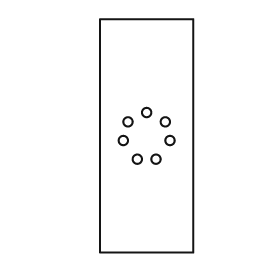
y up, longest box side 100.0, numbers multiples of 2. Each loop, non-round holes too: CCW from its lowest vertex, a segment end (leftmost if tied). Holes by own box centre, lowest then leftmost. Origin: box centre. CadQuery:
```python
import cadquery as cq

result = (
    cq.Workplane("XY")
    .moveTo(-20.0, -50.0)
    .lineTo(20.0, -50.0)
    .lineTo(20.0, 50.0)
    .lineTo(-20.0, 50.0)
    .close()
    .moveTo(-4.0, -10.0)
    .circle(2.0)
    .moveTo(4.0, -10.0)
    .circle(2.0)
    .moveTo(-10.0, -2.0)
    .circle(2.0)
    .moveTo(10.0, -2.0)
    .circle(2.0)
    .moveTo(-8.0, 6.0)
    .circle(2.0)
    .moveTo(8.0, 6.0)
    .circle(2.0)
    .moveTo(0.0, 10.0)
    .circle(2.0)
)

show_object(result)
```